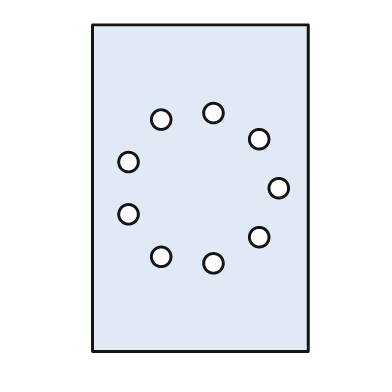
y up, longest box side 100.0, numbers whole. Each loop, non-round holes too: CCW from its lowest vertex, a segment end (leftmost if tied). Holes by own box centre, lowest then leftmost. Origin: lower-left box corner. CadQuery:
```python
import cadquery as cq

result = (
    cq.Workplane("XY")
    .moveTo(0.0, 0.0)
    .lineTo(66.0, 0.0)
    .lineTo(66.0, 100.0)
    .lineTo(0.0, 100.0)
    .close()
    .moveTo(37.0, 27.0)
    .circle(3.0)
    .moveTo(21.0, 29.0)
    .circle(3.0)
    .moveTo(51.0, 35.0)
    .circle(3.0)
    .moveTo(11.0, 42.0)
    .circle(3.0)
    .moveTo(57.0, 50.0)
    .circle(3.0)
    .moveTo(11.0, 58.0)
    .circle(3.0)
    .moveTo(51.0, 65.0)
    .circle(3.0)
    .moveTo(21.0, 71.0)
    .circle(3.0)
    .moveTo(37.0, 73.0)
    .circle(3.0)
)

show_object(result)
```